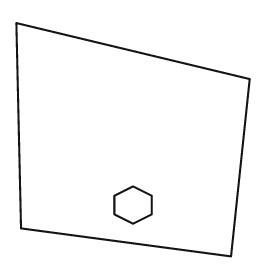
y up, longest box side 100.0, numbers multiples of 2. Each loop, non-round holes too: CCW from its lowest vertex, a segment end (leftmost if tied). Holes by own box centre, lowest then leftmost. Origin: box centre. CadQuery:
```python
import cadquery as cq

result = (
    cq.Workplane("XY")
    .moveTo(42.0, -50.0)
    .lineTo(50.0, 26.0)
    .lineTo(-50.0, 50.0)
    .lineTo(-48.0, -38.0)
    .close()
    .moveTo(0.0, -36.0)
    .lineTo(8.0, -32.0)
    .lineTo(8.0, -24.0)
    .lineTo(0.0, -20.0)
    .lineTo(-8.0, -24.0)
    .lineTo(-8.0, -32.0)
    .close()
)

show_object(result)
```